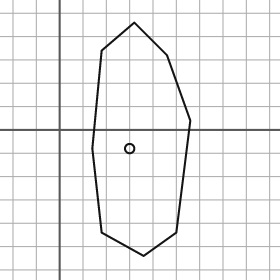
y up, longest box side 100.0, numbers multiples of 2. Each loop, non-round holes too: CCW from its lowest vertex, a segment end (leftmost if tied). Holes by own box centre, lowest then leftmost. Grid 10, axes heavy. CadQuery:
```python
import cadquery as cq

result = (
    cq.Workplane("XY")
    .moveTo(36.0, -54.0)
    .lineTo(50.0, -44.0)
    .lineTo(56.0, 4.0)
    .lineTo(46.0, 32.0)
    .lineTo(32.0, 46.0)
    .lineTo(18.0, 34.0)
    .lineTo(14.0, -8.0)
    .lineTo(18.0, -44.0)
    .close()
    .moveTo(30.0, -8.0)
    .circle(2.0)
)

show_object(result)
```